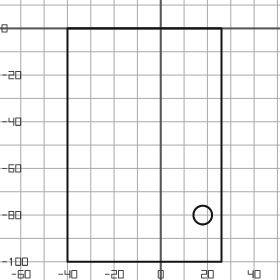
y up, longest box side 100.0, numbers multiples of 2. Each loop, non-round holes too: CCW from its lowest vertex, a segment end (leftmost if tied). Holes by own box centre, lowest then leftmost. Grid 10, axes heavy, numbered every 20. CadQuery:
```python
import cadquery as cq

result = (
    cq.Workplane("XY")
    .moveTo(-40.0, -100.0)
    .lineTo(26.0, -100.0)
    .lineTo(26.0, 0.0)
    .lineTo(-40.0, 0.0)
    .close()
    .moveTo(18.0, -80.0)
    .circle(4.0)
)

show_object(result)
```